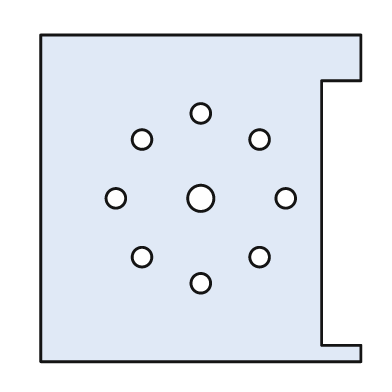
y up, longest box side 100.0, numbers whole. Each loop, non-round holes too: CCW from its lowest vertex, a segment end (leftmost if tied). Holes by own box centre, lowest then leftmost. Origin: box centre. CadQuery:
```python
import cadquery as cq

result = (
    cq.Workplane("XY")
    .moveTo(-49.0, -50.0)
    .lineTo(49.0, -50.0)
    .lineTo(49.0, -45.0)
    .lineTo(37.0, -45.0)
    .lineTo(37.0, 36.0)
    .lineTo(49.0, 36.0)
    .lineTo(49.0, 50.0)
    .lineTo(-49.0, 50.0)
    .close()
    .moveTo(0.0, -26.0)
    .circle(3.0)
    .moveTo(-18.0, -18.0)
    .circle(3.0)
    .moveTo(18.0, -18.0)
    .circle(3.0)
    .moveTo(-26.0, 0.0)
    .circle(3.0)
    .moveTo(0.0, 0.0)
    .circle(4.0)
    .moveTo(26.0, 0.0)
    .circle(3.0)
    .moveTo(-18.0, 18.0)
    .circle(3.0)
    .moveTo(18.0, 18.0)
    .circle(3.0)
    .moveTo(0.0, 26.0)
    .circle(3.0)
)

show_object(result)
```